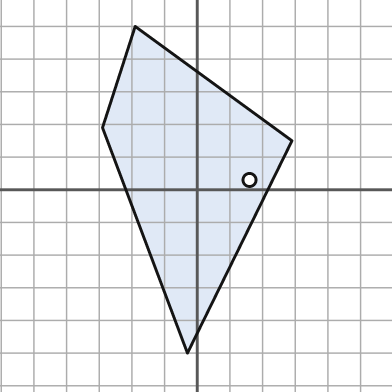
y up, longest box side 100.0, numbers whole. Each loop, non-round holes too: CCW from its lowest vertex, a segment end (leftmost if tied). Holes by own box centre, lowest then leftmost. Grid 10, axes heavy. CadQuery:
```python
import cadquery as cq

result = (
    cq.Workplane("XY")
    .moveTo(-3.0, -50.0)
    .lineTo(29.0, 15.0)
    .lineTo(-19.0, 50.0)
    .lineTo(-29.0, 19.0)
    .close()
    .moveTo(16.0, 3.0)
    .circle(2.0)
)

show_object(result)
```